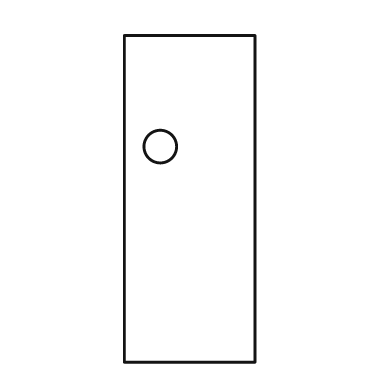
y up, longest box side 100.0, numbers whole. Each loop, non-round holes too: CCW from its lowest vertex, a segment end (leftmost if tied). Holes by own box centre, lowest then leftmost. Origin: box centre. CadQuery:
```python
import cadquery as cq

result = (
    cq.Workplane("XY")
    .moveTo(-20.0, -50.0)
    .lineTo(20.0, -50.0)
    .lineTo(20.0, 50.0)
    .lineTo(-20.0, 50.0)
    .close()
    .moveTo(-9.0, 16.0)
    .circle(5.0)
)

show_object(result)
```